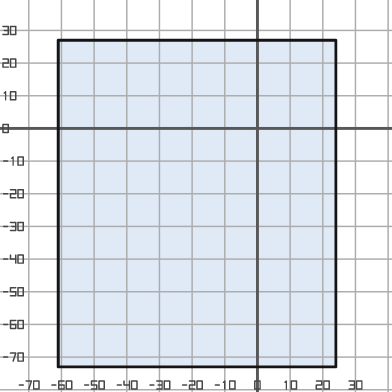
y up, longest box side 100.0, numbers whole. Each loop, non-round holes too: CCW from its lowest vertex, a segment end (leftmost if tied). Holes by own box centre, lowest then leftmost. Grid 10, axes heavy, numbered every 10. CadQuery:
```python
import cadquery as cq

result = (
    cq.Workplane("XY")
    .moveTo(-61.0, -73.0)
    .lineTo(24.0, -73.0)
    .lineTo(24.0, 27.0)
    .lineTo(-61.0, 27.0)
    .close()
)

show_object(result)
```